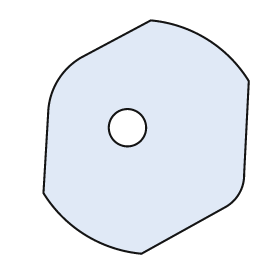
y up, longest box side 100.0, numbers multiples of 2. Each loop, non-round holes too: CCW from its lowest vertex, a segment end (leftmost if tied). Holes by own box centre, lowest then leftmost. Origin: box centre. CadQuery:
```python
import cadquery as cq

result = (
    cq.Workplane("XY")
    .moveTo(-2.0, -50.0)
    .lineTo(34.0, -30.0)
    .threePointArc((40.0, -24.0), (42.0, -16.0))
    .lineTo(44.0, 24.0)
    .threePointArc((26.0, 42.0), (2.0, 50.0))
    .lineTo(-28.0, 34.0)
    .threePointArc((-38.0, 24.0), (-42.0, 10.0))
    .lineTo(-44.0, -24.0)
    .threePointArc((-26.0, -42.0), (-2.0, -50.0))
    .close()
    .moveTo(-8.0, 4.0)
    .circle(8.0)
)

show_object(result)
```